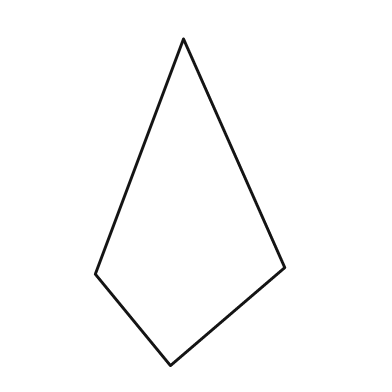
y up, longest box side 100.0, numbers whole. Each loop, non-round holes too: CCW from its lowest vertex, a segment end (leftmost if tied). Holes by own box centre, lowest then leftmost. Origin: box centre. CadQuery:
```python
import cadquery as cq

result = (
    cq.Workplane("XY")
    .moveTo(-6.0, -50.0)
    .lineTo(29.0, -20.0)
    .lineTo(-2.0, 50.0)
    .lineTo(-29.0, -22.0)
    .close()
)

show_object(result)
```